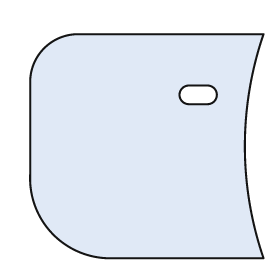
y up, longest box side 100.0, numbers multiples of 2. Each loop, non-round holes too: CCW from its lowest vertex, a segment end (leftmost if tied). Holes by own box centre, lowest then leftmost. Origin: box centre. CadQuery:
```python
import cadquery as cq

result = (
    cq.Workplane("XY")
    .moveTo(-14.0, -48.0)
    .lineTo(50.0, -48.0)
    .threePointArc((42.0, 0.0), (50.0, 48.0))
    .lineTo(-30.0, 48.0)
    .threePointArc((-44.0, 42.0), (-50.0, 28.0))
    .lineTo(-50.0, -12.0)
    .threePointArc((-40.0, -38.0), (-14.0, -48.0))
    .close()
    .moveTo(18.0, 18.0)
    .lineTo(26.0, 18.0)
    .threePointArc((30.0, 22.0), (26.0, 26.0))
    .lineTo(18.0, 26.0)
    .threePointArc((14.0, 22.0), (18.0, 18.0))
    .close()
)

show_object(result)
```